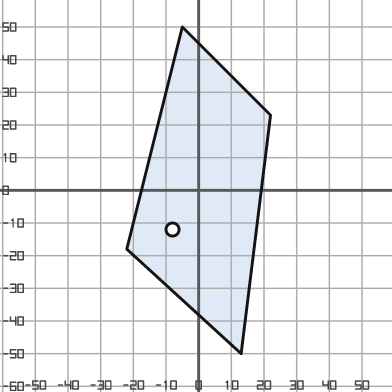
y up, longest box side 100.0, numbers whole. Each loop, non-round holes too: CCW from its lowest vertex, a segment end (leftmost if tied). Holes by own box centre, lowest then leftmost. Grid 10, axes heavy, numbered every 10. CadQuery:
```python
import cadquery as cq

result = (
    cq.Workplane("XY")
    .moveTo(13.0, -50.0)
    .lineTo(22.0, 23.0)
    .lineTo(-5.0, 50.0)
    .lineTo(-22.0, -18.0)
    .close()
    .moveTo(-8.0, -12.0)
    .circle(2.0)
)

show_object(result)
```